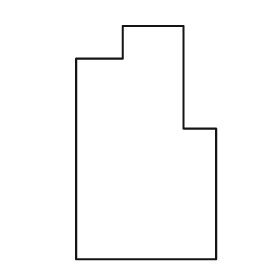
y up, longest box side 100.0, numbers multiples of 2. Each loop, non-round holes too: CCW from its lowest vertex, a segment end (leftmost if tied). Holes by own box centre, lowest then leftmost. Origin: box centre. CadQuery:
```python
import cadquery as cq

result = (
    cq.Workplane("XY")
    .moveTo(-30.0, -50.0)
    .lineTo(30.0, -50.0)
    .lineTo(30.0, 6.0)
    .lineTo(16.0, 6.0)
    .lineTo(16.0, 50.0)
    .lineTo(-10.0, 50.0)
    .lineTo(-10.0, 36.0)
    .lineTo(-30.0, 36.0)
    .close()
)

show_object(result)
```